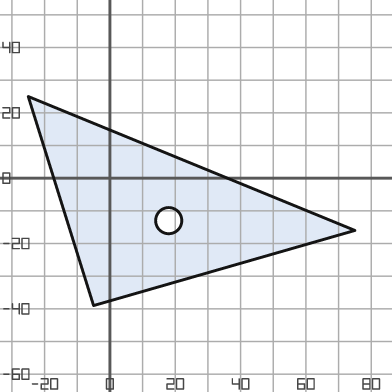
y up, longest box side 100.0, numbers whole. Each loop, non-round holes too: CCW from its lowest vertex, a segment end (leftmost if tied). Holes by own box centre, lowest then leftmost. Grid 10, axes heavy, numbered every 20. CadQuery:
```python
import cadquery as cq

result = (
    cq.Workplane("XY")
    .moveTo(-5.0, -39.0)
    .lineTo(75.0, -16.0)
    .lineTo(-25.0, 25.0)
    .close()
    .moveTo(18.0, -13.0)
    .circle(4.0)
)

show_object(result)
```